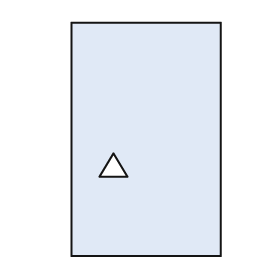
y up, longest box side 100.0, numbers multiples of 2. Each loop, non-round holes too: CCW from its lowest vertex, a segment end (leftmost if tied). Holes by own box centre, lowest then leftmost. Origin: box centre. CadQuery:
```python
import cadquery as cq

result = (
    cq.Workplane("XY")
    .moveTo(-32.0, -50.0)
    .lineTo(32.0, -50.0)
    .lineTo(32.0, 50.0)
    .lineTo(-32.0, 50.0)
    .close()
    .moveTo(-20.0, -16.0)
    .lineTo(-8.0, -16.0)
    .lineTo(-14.0, -6.0)
    .close()
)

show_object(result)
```